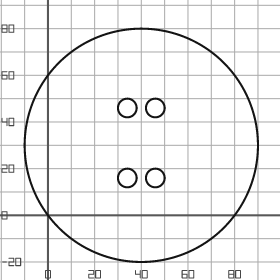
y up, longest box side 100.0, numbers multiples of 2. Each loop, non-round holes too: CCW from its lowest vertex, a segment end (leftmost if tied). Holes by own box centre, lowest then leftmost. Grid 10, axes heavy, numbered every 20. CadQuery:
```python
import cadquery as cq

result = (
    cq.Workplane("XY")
    .moveTo(40.0, 30.0)
    .circle(50.0)
    .moveTo(34.0, 16.0)
    .circle(4.0)
    .moveTo(46.0, 16.0)
    .circle(4.0)
    .moveTo(34.0, 46.0)
    .circle(4.0)
    .moveTo(46.0, 46.0)
    .circle(4.0)
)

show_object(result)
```